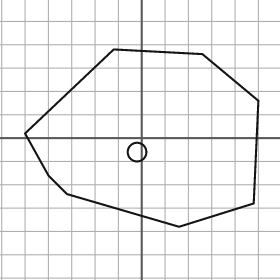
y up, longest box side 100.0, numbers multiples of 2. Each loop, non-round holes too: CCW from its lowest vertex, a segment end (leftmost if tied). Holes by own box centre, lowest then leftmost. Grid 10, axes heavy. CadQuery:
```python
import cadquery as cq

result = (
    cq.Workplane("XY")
    .moveTo(16.0, -38.0)
    .lineTo(48.0, -28.0)
    .lineTo(50.0, 16.0)
    .lineTo(26.0, 36.0)
    .lineTo(-12.0, 38.0)
    .lineTo(-50.0, 2.0)
    .lineTo(-40.0, -16.0)
    .lineTo(-32.0, -24.0)
    .close()
    .moveTo(-2.0, -6.0)
    .circle(4.0)
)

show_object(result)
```